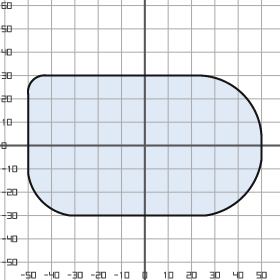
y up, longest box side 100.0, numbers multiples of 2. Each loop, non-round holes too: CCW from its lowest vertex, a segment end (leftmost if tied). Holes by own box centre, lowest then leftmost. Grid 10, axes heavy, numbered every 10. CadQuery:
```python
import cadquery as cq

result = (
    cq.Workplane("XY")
    .moveTo(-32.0, -30.0)
    .lineTo(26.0, -30.0)
    .threePointArc((42.0, -22.0), (50.0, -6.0))
    .lineTo(50.0, 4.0)
    .threePointArc((42.0, 22.0), (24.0, 30.0))
    .lineTo(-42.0, 30.0)
    .threePointArc((-48.0, 28.0), (-50.0, 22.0))
    .lineTo(-50.0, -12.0)
    .threePointArc((-44.0, -24.0), (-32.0, -30.0))
    .close()
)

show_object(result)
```